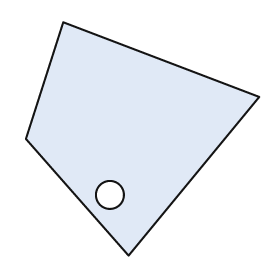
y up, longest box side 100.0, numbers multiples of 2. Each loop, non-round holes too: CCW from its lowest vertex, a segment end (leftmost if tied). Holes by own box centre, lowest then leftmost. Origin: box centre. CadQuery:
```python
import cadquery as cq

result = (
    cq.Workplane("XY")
    .moveTo(-6.0, -50.0)
    .lineTo(50.0, 18.0)
    .lineTo(-34.0, 50.0)
    .lineTo(-50.0, 0.0)
    .close()
    .moveTo(-14.0, -24.0)
    .circle(6.0)
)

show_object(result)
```